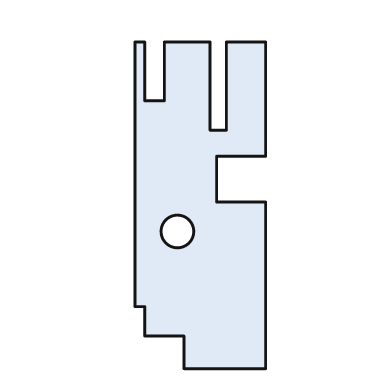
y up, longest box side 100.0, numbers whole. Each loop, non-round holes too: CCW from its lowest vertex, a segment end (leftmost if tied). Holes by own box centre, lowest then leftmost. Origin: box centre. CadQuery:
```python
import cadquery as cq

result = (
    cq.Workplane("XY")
    .moveTo(-5.0, -50.0)
    .lineTo(20.0, -50.0)
    .lineTo(20.0, 1.0)
    .lineTo(5.0, 1.0)
    .lineTo(5.0, 15.0)
    .lineTo(20.0, 15.0)
    .lineTo(20.0, 50.0)
    .lineTo(8.0, 50.0)
    .lineTo(8.0, 23.0)
    .lineTo(3.0, 23.0)
    .lineTo(3.0, 50.0)
    .lineTo(-11.0, 50.0)
    .lineTo(-11.0, 32.0)
    .lineTo(-17.0, 32.0)
    .lineTo(-17.0, 50.0)
    .lineTo(-20.0, 50.0)
    .lineTo(-20.0, -31.0)
    .lineTo(-17.0, -31.0)
    .lineTo(-17.0, -40.0)
    .lineTo(-5.0, -40.0)
    .close()
    .moveTo(-7.0, -8.0)
    .circle(5.0)
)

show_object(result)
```